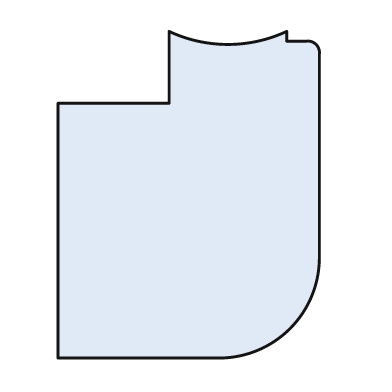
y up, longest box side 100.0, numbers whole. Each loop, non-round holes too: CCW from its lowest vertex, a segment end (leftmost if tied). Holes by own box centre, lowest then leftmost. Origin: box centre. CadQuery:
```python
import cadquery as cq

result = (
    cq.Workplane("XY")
    .moveTo(-40.0, -50.0)
    .lineTo(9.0, -50.0)
    .threePointArc((31.0, -41.0), (40.0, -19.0))
    .lineTo(40.0, 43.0)
    .threePointArc((39.0, 46.0), (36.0, 47.0))
    .lineTo(30.0, 47.0)
    .lineTo(30.0, 50.0)
    .threePointArc((12.0, 46.0), (-6.0, 50.0))
    .lineTo(-6.0, 28.0)
    .lineTo(-40.0, 28.0)
    .close()
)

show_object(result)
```